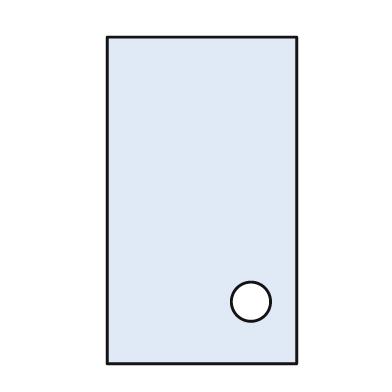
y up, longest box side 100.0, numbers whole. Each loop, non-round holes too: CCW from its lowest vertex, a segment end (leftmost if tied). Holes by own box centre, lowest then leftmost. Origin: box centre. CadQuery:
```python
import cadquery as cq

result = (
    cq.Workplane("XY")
    .moveTo(-29.0, -50.0)
    .lineTo(29.0, -50.0)
    .lineTo(29.0, 50.0)
    .lineTo(-29.0, 50.0)
    .close()
    .moveTo(15.0, -31.0)
    .circle(6.0)
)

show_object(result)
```